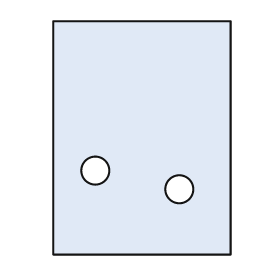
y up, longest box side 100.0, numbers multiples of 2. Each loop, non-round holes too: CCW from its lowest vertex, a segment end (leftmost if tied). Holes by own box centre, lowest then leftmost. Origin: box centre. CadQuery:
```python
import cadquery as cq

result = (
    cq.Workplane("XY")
    .moveTo(-38.0, -50.0)
    .lineTo(38.0, -50.0)
    .lineTo(38.0, 50.0)
    .lineTo(-38.0, 50.0)
    .close()
    .moveTo(16.0, -22.0)
    .circle(6.0)
    .moveTo(-20.0, -14.0)
    .circle(6.0)
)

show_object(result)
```